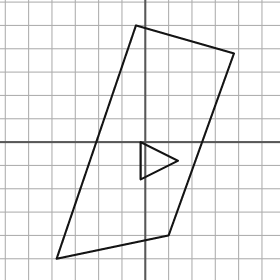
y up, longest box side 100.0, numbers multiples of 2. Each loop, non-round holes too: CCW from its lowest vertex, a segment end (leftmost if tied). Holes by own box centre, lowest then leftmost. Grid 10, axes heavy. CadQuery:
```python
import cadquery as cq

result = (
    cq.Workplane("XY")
    .moveTo(-38.0, -50.0)
    .lineTo(10.0, -40.0)
    .lineTo(38.0, 38.0)
    .lineTo(-4.0, 50.0)
    .close()
    .moveTo(-2.0, -16.0)
    .lineTo(14.0, -8.0)
    .lineTo(-2.0, 0.0)
    .close()
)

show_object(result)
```